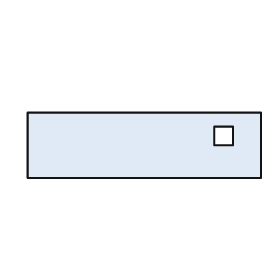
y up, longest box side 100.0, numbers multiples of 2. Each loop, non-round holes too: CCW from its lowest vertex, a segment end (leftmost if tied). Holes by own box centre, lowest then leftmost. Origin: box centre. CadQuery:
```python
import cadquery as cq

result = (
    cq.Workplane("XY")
    .moveTo(-50.0, -14.0)
    .lineTo(50.0, -14.0)
    .lineTo(50.0, 14.0)
    .lineTo(-50.0, 14.0)
    .close()
    .moveTo(30.0, 0.0)
    .lineTo(38.0, 0.0)
    .lineTo(38.0, 8.0)
    .lineTo(30.0, 8.0)
    .close()
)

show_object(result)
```